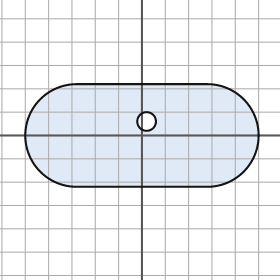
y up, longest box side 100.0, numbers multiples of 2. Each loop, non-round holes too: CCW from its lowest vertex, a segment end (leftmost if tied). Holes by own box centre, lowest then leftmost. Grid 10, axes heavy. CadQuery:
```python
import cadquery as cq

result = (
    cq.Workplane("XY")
    .moveTo(-28.0, -22.0)
    .lineTo(28.0, -22.0)
    .threePointArc((50.0, 0.0), (28.0, 22.0))
    .lineTo(-28.0, 22.0)
    .threePointArc((-50.0, 0.0), (-28.0, -22.0))
    .close()
    .moveTo(2.0, 6.0)
    .circle(4.0)
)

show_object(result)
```